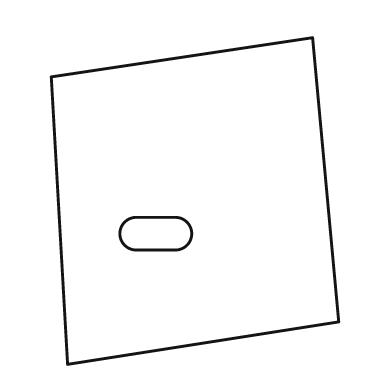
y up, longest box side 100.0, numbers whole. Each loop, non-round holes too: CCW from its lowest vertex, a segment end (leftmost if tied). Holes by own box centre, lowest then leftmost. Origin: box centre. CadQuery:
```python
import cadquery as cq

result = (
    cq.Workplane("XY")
    .moveTo(-39.0, -50.0)
    .lineTo(44.0, -37.0)
    .lineTo(36.0, 50.0)
    .lineTo(-44.0, 38.0)
    .close()
    .moveTo(-18.0, -15.0)
    .lineTo(-6.0, -15.0)
    .threePointArc((-1.0, -10.0), (-6.0, -5.0))
    .lineTo(-18.0, -5.0)
    .threePointArc((-23.0, -10.0), (-18.0, -15.0))
    .close()
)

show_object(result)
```